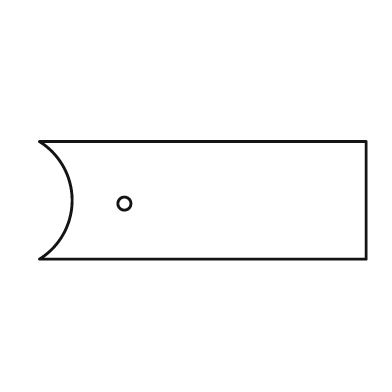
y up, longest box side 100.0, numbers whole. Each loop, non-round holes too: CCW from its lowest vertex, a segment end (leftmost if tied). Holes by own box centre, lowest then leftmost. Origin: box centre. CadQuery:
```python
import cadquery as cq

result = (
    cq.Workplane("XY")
    .moveTo(-50.0, -18.0)
    .lineTo(50.0, -18.0)
    .lineTo(50.0, 18.0)
    .lineTo(-50.0, 18.0)
    .threePointArc((-40.0, 0.0), (-50.0, -18.0))
    .close()
    .moveTo(-24.0, -1.0)
    .circle(2.0)
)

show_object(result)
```